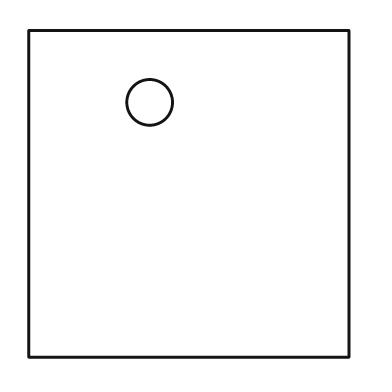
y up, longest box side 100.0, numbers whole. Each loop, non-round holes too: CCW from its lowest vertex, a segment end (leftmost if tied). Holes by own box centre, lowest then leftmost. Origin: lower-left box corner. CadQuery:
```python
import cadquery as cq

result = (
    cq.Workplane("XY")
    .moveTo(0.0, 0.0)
    .lineTo(98.0, 0.0)
    .lineTo(98.0, 100.0)
    .lineTo(0.0, 100.0)
    .close()
    .moveTo(37.0, 78.0)
    .circle(7.0)
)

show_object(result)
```